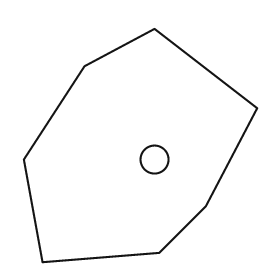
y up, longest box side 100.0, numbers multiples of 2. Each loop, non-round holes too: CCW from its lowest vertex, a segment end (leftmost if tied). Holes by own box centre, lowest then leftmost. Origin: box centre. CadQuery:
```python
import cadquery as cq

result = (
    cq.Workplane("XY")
    .moveTo(-42.0, -50.0)
    .lineTo(8.0, -46.0)
    .lineTo(28.0, -26.0)
    .lineTo(50.0, 16.0)
    .lineTo(6.0, 50.0)
    .lineTo(-24.0, 34.0)
    .lineTo(-50.0, -6.0)
    .close()
    .moveTo(6.0, -6.0)
    .circle(6.0)
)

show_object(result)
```